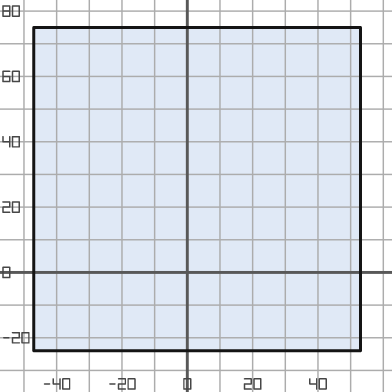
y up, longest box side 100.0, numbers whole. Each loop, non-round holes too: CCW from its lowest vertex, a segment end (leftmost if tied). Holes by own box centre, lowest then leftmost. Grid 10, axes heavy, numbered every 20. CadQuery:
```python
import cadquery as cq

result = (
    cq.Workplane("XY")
    .moveTo(-47.0, -24.0)
    .lineTo(53.0, -24.0)
    .lineTo(53.0, 75.0)
    .lineTo(-47.0, 75.0)
    .close()
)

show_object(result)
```